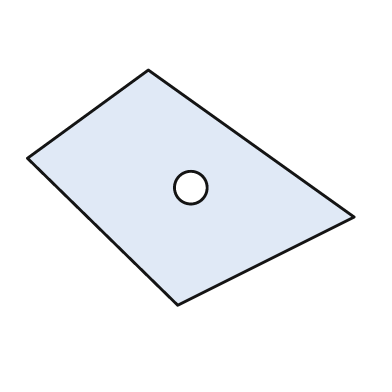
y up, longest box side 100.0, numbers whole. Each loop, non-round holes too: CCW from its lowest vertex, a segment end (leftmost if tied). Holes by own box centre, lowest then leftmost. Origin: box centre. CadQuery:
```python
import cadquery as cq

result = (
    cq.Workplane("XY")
    .moveTo(-4.0, -36.0)
    .lineTo(50.0, -9.0)
    .lineTo(-13.0, 36.0)
    .lineTo(-50.0, 9.0)
    .close()
    .moveTo(0.0, 0.0)
    .circle(5.0)
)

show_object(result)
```